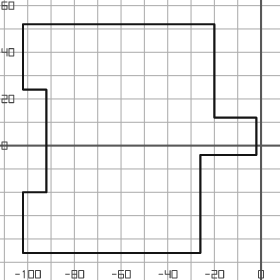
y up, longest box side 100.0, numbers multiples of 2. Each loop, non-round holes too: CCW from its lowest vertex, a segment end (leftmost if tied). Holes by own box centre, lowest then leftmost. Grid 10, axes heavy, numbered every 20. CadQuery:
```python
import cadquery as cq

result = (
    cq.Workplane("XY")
    .moveTo(-102.0, -46.0)
    .lineTo(-26.0, -46.0)
    .lineTo(-26.0, -4.0)
    .lineTo(-2.0, -4.0)
    .lineTo(-2.0, 12.0)
    .lineTo(-20.0, 12.0)
    .lineTo(-20.0, 52.0)
    .lineTo(-102.0, 52.0)
    .lineTo(-102.0, 24.0)
    .lineTo(-92.0, 24.0)
    .lineTo(-92.0, -20.0)
    .lineTo(-102.0, -20.0)
    .close()
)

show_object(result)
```